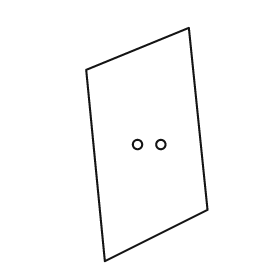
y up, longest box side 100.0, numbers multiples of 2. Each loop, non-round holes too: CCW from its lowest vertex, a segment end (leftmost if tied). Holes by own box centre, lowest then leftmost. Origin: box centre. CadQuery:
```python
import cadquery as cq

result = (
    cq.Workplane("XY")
    .moveTo(-18.0, -50.0)
    .lineTo(26.0, -28.0)
    .lineTo(18.0, 50.0)
    .lineTo(-26.0, 32.0)
    .close()
    .moveTo(-4.0, 0.0)
    .circle(2.0)
    .moveTo(6.0, 0.0)
    .circle(2.0)
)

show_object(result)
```